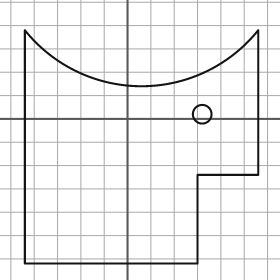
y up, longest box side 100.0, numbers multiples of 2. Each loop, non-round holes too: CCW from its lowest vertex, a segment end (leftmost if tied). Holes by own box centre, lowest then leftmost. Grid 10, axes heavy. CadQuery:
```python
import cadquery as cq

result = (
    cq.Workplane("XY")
    .moveTo(-44.0, -62.0)
    .lineTo(30.0, -62.0)
    .lineTo(30.0, -24.0)
    .lineTo(56.0, -24.0)
    .lineTo(56.0, 38.0)
    .threePointArc((6.0, 14.0), (-44.0, 38.0))
    .close()
    .moveTo(32.0, 2.0)
    .circle(4.0)
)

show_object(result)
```